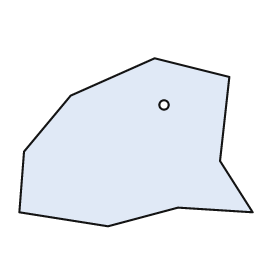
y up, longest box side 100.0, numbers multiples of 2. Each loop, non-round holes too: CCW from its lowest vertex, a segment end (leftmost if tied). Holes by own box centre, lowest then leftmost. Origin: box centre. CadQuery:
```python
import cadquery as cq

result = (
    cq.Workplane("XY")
    .moveTo(-12.0, -36.0)
    .lineTo(18.0, -28.0)
    .lineTo(50.0, -30.0)
    .lineTo(36.0, -8.0)
    .lineTo(40.0, 28.0)
    .lineTo(8.0, 36.0)
    .lineTo(-28.0, 20.0)
    .lineTo(-48.0, -4.0)
    .lineTo(-50.0, -30.0)
    .close()
    .moveTo(12.0, 16.0)
    .circle(2.0)
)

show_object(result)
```